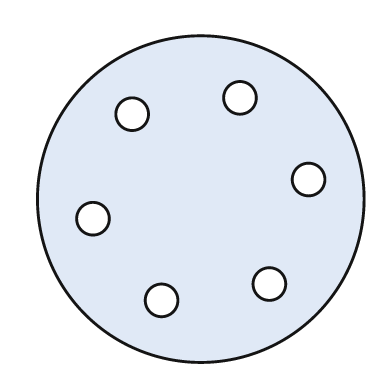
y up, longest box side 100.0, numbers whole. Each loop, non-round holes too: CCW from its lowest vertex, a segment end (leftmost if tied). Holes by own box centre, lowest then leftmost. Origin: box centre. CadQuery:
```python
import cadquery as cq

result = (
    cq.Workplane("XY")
    .moveTo(0.0, 0.0)
    .circle(50.0)
    .moveTo(-12.0, -31.0)
    .circle(5.0)
    .moveTo(21.0, -26.0)
    .circle(5.0)
    .moveTo(-33.0, -6.0)
    .circle(5.0)
    .moveTo(33.0, 6.0)
    .circle(5.0)
    .moveTo(-21.0, 26.0)
    .circle(5.0)
    .moveTo(12.0, 31.0)
    .circle(5.0)
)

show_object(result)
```